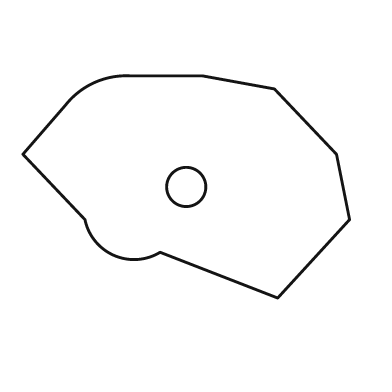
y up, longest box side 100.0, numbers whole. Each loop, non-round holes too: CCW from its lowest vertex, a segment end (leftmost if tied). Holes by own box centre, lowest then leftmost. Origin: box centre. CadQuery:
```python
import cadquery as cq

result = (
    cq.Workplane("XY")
    .moveTo(28.0, -34.0)
    .lineTo(50.0, -10.0)
    .lineTo(46.0, 10.0)
    .lineTo(27.0, 30.0)
    .lineTo(5.0, 34.0)
    .lineTo(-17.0, 34.0)
    .threePointArc((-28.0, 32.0), (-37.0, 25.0))
    .lineTo(-50.0, 10.0)
    .lineTo(-31.0, -10.0)
    .threePointArc((-22.0, -21.0), (-8.0, -20.0))
    .close()
    .moveTo(0.0, 0.0)
    .circle(6.0)
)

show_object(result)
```